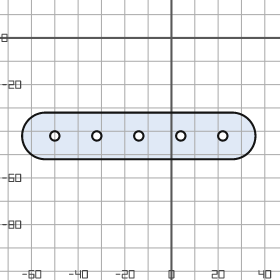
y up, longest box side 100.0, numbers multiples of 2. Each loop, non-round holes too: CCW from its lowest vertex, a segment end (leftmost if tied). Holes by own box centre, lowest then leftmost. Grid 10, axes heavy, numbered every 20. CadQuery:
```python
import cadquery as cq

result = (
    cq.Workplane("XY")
    .moveTo(-54.0, -52.0)
    .lineTo(26.0, -52.0)
    .threePointArc((36.0, -42.0), (26.0, -32.0))
    .lineTo(-54.0, -32.0)
    .threePointArc((-64.0, -42.0), (-54.0, -52.0))
    .close()
    .moveTo(-50.0, -42.0)
    .circle(2.0)
    .moveTo(-32.0, -42.0)
    .circle(2.0)
    .moveTo(-14.0, -42.0)
    .circle(2.0)
    .moveTo(4.0, -42.0)
    .circle(2.0)
    .moveTo(22.0, -42.0)
    .circle(2.0)
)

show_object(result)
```